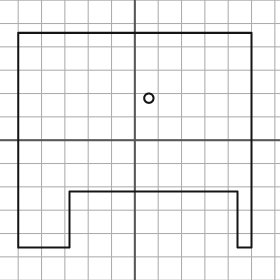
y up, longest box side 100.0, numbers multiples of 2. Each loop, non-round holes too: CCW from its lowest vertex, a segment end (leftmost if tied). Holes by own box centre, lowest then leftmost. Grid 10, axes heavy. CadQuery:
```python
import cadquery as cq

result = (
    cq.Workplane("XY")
    .moveTo(-50.0, -46.0)
    .lineTo(-28.0, -46.0)
    .lineTo(-28.0, -22.0)
    .lineTo(44.0, -22.0)
    .lineTo(44.0, -46.0)
    .lineTo(50.0, -46.0)
    .lineTo(50.0, 46.0)
    .lineTo(-50.0, 46.0)
    .close()
    .moveTo(6.0, 18.0)
    .circle(2.0)
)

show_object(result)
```